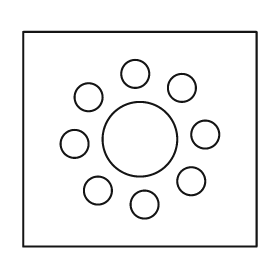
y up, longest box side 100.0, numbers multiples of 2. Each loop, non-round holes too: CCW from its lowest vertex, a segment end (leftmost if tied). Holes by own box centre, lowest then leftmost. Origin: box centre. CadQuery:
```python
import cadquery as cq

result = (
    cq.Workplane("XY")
    .moveTo(-50.0, -46.0)
    .lineTo(50.0, -46.0)
    .lineTo(50.0, 46.0)
    .lineTo(-50.0, 46.0)
    .close()
    .moveTo(2.0, -28.0)
    .circle(6.0)
    .moveTo(-18.0, -22.0)
    .circle(6.0)
    .moveTo(22.0, -18.0)
    .circle(6.0)
    .moveTo(-28.0, -2.0)
    .circle(6.0)
    .moveTo(0.0, 0.0)
    .circle(16.0)
    .moveTo(28.0, 2.0)
    .circle(6.0)
    .moveTo(-22.0, 18.0)
    .circle(6.0)
    .moveTo(18.0, 22.0)
    .circle(6.0)
    .moveTo(-2.0, 28.0)
    .circle(6.0)
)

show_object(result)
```